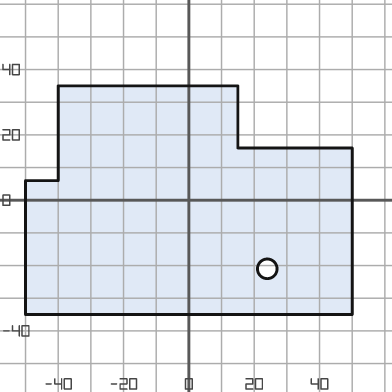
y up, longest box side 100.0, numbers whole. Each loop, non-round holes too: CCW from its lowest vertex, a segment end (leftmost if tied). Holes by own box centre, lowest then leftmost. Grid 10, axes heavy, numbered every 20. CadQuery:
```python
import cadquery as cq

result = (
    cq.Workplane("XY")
    .moveTo(-50.0, -35.0)
    .lineTo(50.0, -35.0)
    .lineTo(50.0, 16.0)
    .lineTo(15.0, 16.0)
    .lineTo(15.0, 35.0)
    .lineTo(-40.0, 35.0)
    .lineTo(-40.0, 6.0)
    .lineTo(-50.0, 6.0)
    .close()
    .moveTo(24.0, -21.0)
    .circle(3.0)
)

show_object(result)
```